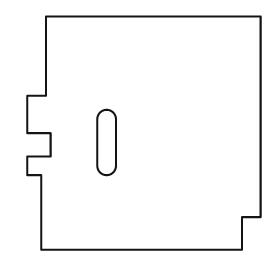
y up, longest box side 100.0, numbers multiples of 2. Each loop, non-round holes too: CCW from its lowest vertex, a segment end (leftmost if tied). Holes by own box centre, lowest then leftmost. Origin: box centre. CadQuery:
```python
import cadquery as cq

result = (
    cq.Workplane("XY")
    .moveTo(-44.0, -50.0)
    .lineTo(42.0, -50.0)
    .lineTo(42.0, -36.0)
    .lineTo(50.0, -36.0)
    .lineTo(50.0, 50.0)
    .lineTo(-42.0, 50.0)
    .lineTo(-42.0, 16.0)
    .lineTo(-50.0, 16.0)
    .lineTo(-50.0, 0.0)
    .lineTo(-40.0, 0.0)
    .lineTo(-40.0, -10.0)
    .lineTo(-50.0, -10.0)
    .lineTo(-50.0, -18.0)
    .lineTo(-44.0, -18.0)
    .close()
    .moveTo(-20.0, -14.0)
    .threePointArc((-16.0, -18.0), (-12.0, -14.0))
    .lineTo(-12.0, 6.0)
    .threePointArc((-16.0, 10.0), (-20.0, 6.0))
    .close()
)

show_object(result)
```